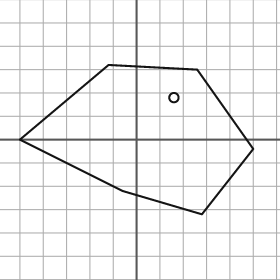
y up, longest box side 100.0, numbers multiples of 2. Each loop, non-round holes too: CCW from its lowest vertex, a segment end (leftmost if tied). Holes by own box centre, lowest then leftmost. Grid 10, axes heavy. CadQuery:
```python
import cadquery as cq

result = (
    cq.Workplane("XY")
    .moveTo(28.0, -32.0)
    .lineTo(50.0, -4.0)
    .lineTo(26.0, 30.0)
    .lineTo(-12.0, 32.0)
    .lineTo(-50.0, 0.0)
    .lineTo(-6.0, -22.0)
    .close()
    .moveTo(16.0, 18.0)
    .circle(2.0)
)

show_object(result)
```